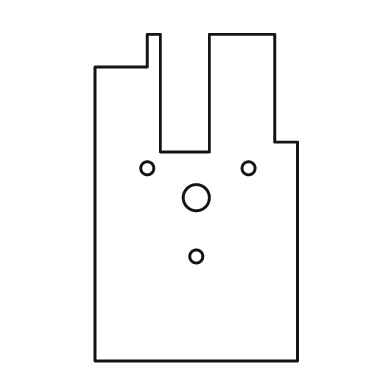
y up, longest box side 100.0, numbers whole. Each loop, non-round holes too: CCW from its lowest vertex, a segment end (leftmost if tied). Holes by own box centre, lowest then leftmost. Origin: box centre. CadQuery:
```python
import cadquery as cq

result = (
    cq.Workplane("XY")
    .moveTo(-31.0, -50.0)
    .lineTo(31.0, -50.0)
    .lineTo(31.0, 17.0)
    .lineTo(24.0, 17.0)
    .lineTo(24.0, 50.0)
    .lineTo(4.0, 50.0)
    .lineTo(4.0, 14.0)
    .lineTo(-11.0, 14.0)
    .lineTo(-11.0, 50.0)
    .lineTo(-15.0, 50.0)
    .lineTo(-15.0, 40.0)
    .lineTo(-31.0, 40.0)
    .close()
    .moveTo(0.0, -18.0)
    .circle(2.0)
    .moveTo(0.0, 0.0)
    .circle(4.0)
    .moveTo(-15.0, 9.0)
    .circle(2.0)
    .moveTo(16.0, 9.0)
    .circle(2.0)
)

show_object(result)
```